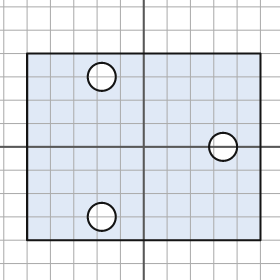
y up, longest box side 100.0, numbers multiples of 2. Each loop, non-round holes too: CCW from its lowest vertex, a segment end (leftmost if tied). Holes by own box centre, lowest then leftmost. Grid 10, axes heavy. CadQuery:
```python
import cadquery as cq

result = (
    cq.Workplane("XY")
    .moveTo(-50.0, -40.0)
    .lineTo(50.0, -40.0)
    .lineTo(50.0, 40.0)
    .lineTo(-50.0, 40.0)
    .close()
    .moveTo(-18.0, -30.0)
    .circle(6.0)
    .moveTo(34.0, 0.0)
    .circle(6.0)
    .moveTo(-18.0, 30.0)
    .circle(6.0)
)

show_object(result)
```